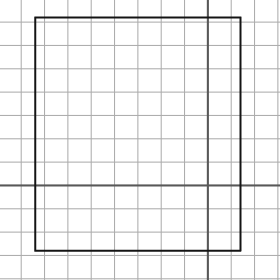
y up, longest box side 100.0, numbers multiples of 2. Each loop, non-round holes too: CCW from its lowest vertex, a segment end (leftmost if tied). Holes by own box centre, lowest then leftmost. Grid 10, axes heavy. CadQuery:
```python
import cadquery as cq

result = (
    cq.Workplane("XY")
    .moveTo(-74.0, -28.0)
    .lineTo(14.0, -28.0)
    .lineTo(14.0, 72.0)
    .lineTo(-74.0, 72.0)
    .close()
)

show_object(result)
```